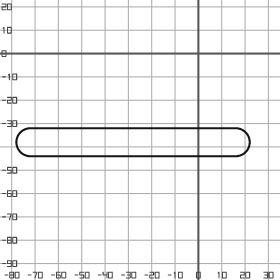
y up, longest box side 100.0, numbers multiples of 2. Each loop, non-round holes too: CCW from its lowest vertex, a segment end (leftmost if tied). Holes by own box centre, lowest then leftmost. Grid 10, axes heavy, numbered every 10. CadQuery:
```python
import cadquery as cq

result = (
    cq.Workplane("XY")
    .moveTo(-72.0, -44.0)
    .lineTo(16.0, -44.0)
    .threePointArc((22.0, -38.0), (16.0, -32.0))
    .lineTo(-72.0, -32.0)
    .threePointArc((-78.0, -38.0), (-72.0, -44.0))
    .close()
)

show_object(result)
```